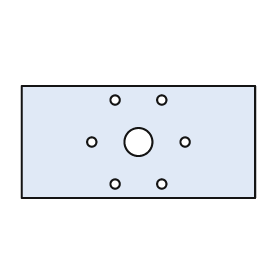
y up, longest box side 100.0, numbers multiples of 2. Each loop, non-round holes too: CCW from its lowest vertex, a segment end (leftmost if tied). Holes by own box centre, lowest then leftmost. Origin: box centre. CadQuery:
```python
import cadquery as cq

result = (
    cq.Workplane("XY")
    .moveTo(-50.0, -24.0)
    .lineTo(50.0, -24.0)
    .lineTo(50.0, 24.0)
    .lineTo(-50.0, 24.0)
    .close()
    .moveTo(-10.0, -18.0)
    .circle(2.0)
    .moveTo(10.0, -18.0)
    .circle(2.0)
    .moveTo(-20.0, 0.0)
    .circle(2.0)
    .moveTo(0.0, 0.0)
    .circle(6.0)
    .moveTo(20.0, 0.0)
    .circle(2.0)
    .moveTo(-10.0, 18.0)
    .circle(2.0)
    .moveTo(10.0, 18.0)
    .circle(2.0)
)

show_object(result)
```